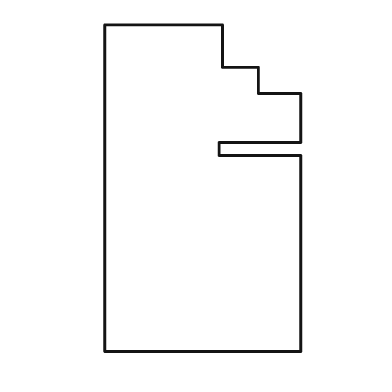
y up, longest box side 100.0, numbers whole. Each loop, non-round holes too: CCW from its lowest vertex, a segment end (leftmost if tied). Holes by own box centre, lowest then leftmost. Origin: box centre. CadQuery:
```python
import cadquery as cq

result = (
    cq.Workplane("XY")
    .moveTo(-30.0, -50.0)
    .lineTo(30.0, -50.0)
    .lineTo(30.0, 10.0)
    .lineTo(5.0, 10.0)
    .lineTo(5.0, 14.0)
    .lineTo(30.0, 14.0)
    .lineTo(30.0, 29.0)
    .lineTo(17.0, 29.0)
    .lineTo(17.0, 37.0)
    .lineTo(6.0, 37.0)
    .lineTo(6.0, 50.0)
    .lineTo(-30.0, 50.0)
    .close()
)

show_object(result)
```